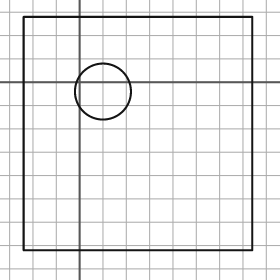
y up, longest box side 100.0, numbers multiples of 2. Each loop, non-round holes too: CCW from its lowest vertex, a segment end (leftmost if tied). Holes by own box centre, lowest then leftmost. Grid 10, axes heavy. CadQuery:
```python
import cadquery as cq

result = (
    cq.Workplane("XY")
    .moveTo(-24.0, -72.0)
    .lineTo(74.0, -72.0)
    .lineTo(74.0, 28.0)
    .lineTo(-24.0, 28.0)
    .close()
    .moveTo(10.0, -4.0)
    .circle(12.0)
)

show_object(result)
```